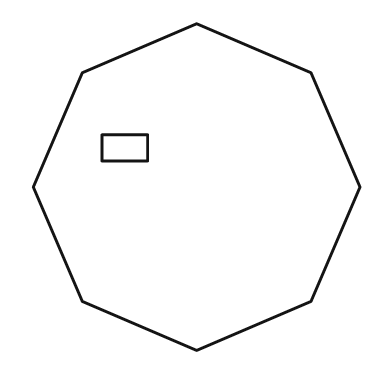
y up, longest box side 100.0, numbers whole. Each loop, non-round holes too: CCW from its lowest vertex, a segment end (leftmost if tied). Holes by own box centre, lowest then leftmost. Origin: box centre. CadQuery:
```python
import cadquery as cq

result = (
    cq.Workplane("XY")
    .moveTo(0.0, -50.0)
    .lineTo(35.0, -35.0)
    .lineTo(50.0, 0.0)
    .lineTo(35.0, 35.0)
    .lineTo(0.0, 50.0)
    .lineTo(-35.0, 35.0)
    .lineTo(-50.0, 0.0)
    .lineTo(-35.0, -35.0)
    .close()
    .moveTo(-29.0, 8.0)
    .lineTo(-15.0, 8.0)
    .lineTo(-15.0, 16.0)
    .lineTo(-29.0, 16.0)
    .close()
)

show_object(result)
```